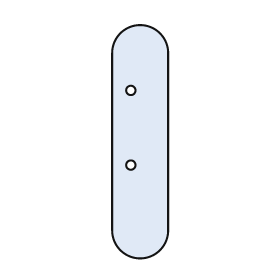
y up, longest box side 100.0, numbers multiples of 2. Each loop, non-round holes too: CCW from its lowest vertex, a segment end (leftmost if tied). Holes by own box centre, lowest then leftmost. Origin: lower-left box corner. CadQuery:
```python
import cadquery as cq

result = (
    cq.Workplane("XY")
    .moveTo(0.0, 12.0)
    .threePointArc((12.0, 0.0), (24.0, 12.0))
    .lineTo(24.0, 88.0)
    .threePointArc((12.0, 100.0), (0.0, 88.0))
    .close()
    .moveTo(8.0, 40.0)
    .circle(2.0)
    .moveTo(8.0, 72.0)
    .circle(2.0)
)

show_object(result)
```